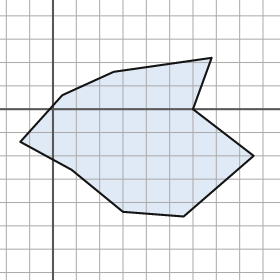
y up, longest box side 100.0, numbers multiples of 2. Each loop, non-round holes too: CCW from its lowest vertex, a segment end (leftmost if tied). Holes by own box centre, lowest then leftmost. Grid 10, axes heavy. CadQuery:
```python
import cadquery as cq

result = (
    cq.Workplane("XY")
    .moveTo(56.0, -46.0)
    .lineTo(86.0, -20.0)
    .lineTo(60.0, 0.0)
    .lineTo(68.0, 22.0)
    .lineTo(26.0, 16.0)
    .lineTo(4.0, 6.0)
    .lineTo(-14.0, -14.0)
    .lineTo(8.0, -26.0)
    .lineTo(30.0, -44.0)
    .close()
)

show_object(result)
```